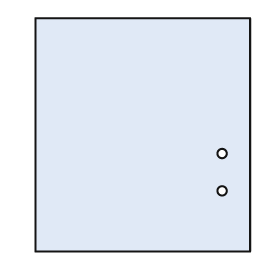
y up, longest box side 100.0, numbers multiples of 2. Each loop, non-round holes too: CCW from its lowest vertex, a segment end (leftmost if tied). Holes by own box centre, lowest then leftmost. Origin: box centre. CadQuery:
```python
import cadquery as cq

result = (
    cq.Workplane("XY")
    .moveTo(-46.0, -50.0)
    .lineTo(46.0, -50.0)
    .lineTo(46.0, 50.0)
    .lineTo(-46.0, 50.0)
    .close()
    .moveTo(34.0, -24.0)
    .circle(2.0)
    .moveTo(34.0, -8.0)
    .circle(2.0)
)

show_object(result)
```